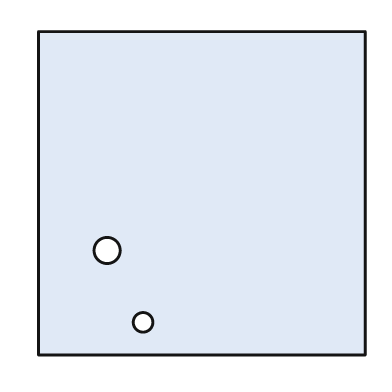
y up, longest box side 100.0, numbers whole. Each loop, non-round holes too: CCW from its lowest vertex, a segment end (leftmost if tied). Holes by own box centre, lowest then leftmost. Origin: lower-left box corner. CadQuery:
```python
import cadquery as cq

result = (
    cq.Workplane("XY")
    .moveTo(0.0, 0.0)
    .lineTo(100.0, 0.0)
    .lineTo(100.0, 99.0)
    .lineTo(0.0, 99.0)
    .close()
    .moveTo(32.0, 10.0)
    .circle(3.0)
    .moveTo(21.0, 32.0)
    .circle(4.0)
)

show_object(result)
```